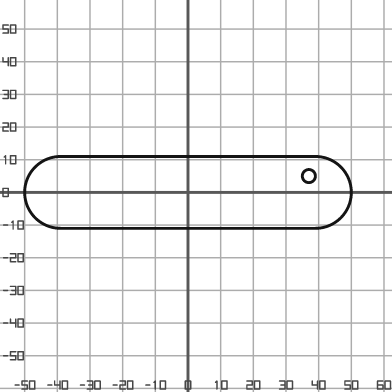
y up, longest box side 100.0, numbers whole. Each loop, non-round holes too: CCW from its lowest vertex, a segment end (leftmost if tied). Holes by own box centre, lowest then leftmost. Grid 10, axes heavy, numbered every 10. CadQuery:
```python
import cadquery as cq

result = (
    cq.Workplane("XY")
    .moveTo(-39.0, -11.0)
    .lineTo(39.0, -11.0)
    .threePointArc((50.0, 0.0), (39.0, 11.0))
    .lineTo(-39.0, 11.0)
    .threePointArc((-50.0, 0.0), (-39.0, -11.0))
    .close()
    .moveTo(37.0, 5.0)
    .circle(2.0)
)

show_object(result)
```